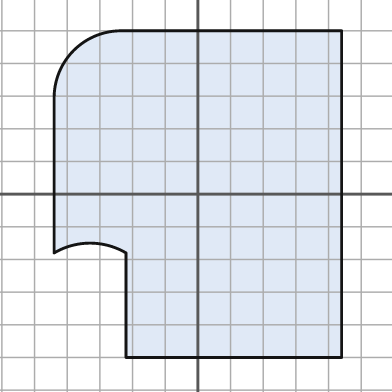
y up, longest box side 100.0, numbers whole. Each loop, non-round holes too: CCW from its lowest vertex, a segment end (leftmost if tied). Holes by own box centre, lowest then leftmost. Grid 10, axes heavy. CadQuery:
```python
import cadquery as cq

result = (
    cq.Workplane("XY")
    .moveTo(-22.0, -50.0)
    .lineTo(44.0, -50.0)
    .lineTo(44.0, 50.0)
    .lineTo(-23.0, 50.0)
    .threePointArc((-38.0, 44.0), (-44.0, 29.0))
    .lineTo(-44.0, -18.0)
    .threePointArc((-33.0, -15.0), (-22.0, -18.0))
    .close()
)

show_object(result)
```